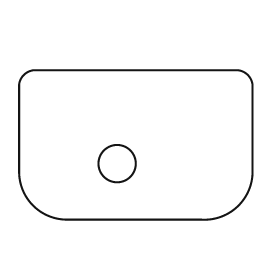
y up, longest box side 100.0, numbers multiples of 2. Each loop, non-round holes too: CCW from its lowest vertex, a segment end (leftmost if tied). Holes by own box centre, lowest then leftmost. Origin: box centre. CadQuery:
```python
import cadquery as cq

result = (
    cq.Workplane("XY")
    .moveTo(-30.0, -32.0)
    .lineTo(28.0, -32.0)
    .threePointArc((44.0, -26.0), (50.0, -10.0))
    .lineTo(50.0, 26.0)
    .threePointArc((48.0, 30.0), (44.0, 32.0))
    .lineTo(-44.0, 32.0)
    .threePointArc((-48.0, 30.0), (-50.0, 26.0))
    .lineTo(-50.0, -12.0)
    .threePointArc((-44.0, -26.0), (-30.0, -32.0))
    .close()
    .moveTo(-8.0, -8.0)
    .circle(8.0)
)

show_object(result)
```